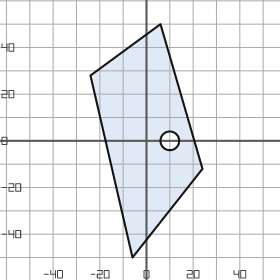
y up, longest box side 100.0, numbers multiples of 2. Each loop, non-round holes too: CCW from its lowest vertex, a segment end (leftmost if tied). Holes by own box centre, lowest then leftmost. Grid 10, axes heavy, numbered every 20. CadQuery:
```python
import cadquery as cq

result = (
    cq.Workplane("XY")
    .moveTo(-6.0, -50.0)
    .lineTo(24.0, -12.0)
    .lineTo(6.0, 50.0)
    .lineTo(-24.0, 28.0)
    .close()
    .moveTo(10.0, 0.0)
    .circle(4.0)
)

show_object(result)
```